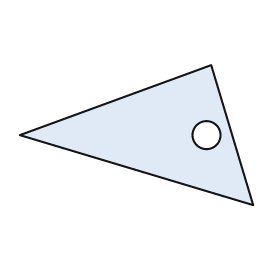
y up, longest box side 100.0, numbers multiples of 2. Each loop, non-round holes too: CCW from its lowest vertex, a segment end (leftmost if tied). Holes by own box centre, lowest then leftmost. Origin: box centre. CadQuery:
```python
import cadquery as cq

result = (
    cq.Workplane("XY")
    .moveTo(50.0, -30.0)
    .lineTo(32.0, 30.0)
    .lineTo(-50.0, 0.0)
    .close()
    .moveTo(30.0, 0.0)
    .circle(6.0)
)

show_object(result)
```